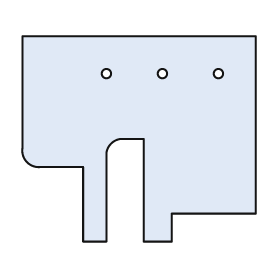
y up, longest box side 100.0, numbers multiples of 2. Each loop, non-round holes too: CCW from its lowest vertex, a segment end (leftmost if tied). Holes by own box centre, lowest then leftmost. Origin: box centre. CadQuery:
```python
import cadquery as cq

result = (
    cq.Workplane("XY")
    .moveTo(-24.0, -44.0)
    .lineTo(-14.0, -44.0)
    .lineTo(-14.0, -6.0)
    .threePointArc((-12.0, -2.0), (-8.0, 0.0))
    .lineTo(2.0, 0.0)
    .lineTo(2.0, -44.0)
    .lineTo(14.0, -44.0)
    .lineTo(14.0, -32.0)
    .lineTo(50.0, -32.0)
    .lineTo(50.0, 44.0)
    .lineTo(-50.0, 44.0)
    .lineTo(-50.0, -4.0)
    .threePointArc((-48.0, -10.0), (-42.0, -12.0))
    .lineTo(-24.0, -12.0)
    .close()
    .moveTo(-14.0, 28.0)
    .circle(2.0)
    .moveTo(10.0, 28.0)
    .circle(2.0)
    .moveTo(34.0, 28.0)
    .circle(2.0)
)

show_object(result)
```